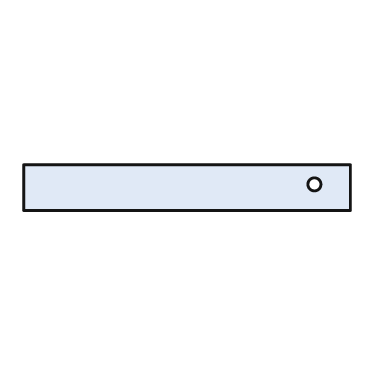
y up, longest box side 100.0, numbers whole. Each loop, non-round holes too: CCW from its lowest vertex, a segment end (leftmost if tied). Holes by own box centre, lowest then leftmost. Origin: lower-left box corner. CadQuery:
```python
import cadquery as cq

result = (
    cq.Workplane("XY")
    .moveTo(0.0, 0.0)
    .lineTo(100.0, 0.0)
    .lineTo(100.0, 14.0)
    .lineTo(0.0, 14.0)
    .close()
    .moveTo(89.0, 8.0)
    .circle(2.0)
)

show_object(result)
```